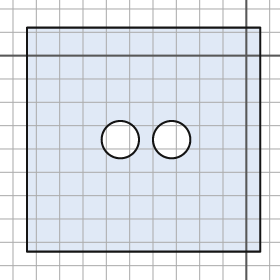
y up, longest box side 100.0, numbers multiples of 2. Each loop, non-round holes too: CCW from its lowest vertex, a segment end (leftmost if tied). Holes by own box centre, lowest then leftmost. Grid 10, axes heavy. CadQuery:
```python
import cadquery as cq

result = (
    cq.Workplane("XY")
    .moveTo(-94.0, -84.0)
    .lineTo(6.0, -84.0)
    .lineTo(6.0, 12.0)
    .lineTo(-94.0, 12.0)
    .close()
    .moveTo(-54.0, -36.0)
    .circle(8.0)
    .moveTo(-32.0, -36.0)
    .circle(8.0)
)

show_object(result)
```